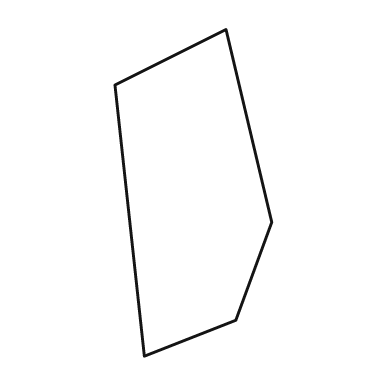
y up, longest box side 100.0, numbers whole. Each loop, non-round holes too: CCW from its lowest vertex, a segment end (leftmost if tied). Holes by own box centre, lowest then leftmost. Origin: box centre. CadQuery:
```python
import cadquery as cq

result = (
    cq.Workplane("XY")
    .moveTo(-15.0, -50.0)
    .lineTo(13.0, -39.0)
    .lineTo(24.0, -9.0)
    .lineTo(10.0, 50.0)
    .lineTo(-24.0, 33.0)
    .close()
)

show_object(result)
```